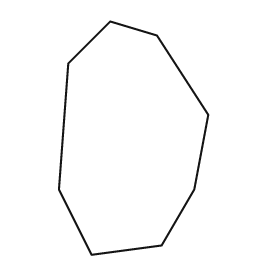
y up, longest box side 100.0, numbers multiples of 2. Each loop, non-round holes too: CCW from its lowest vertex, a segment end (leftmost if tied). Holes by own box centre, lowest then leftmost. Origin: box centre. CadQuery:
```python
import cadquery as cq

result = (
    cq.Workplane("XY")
    .moveTo(-18.0, -50.0)
    .lineTo(12.0, -46.0)
    .lineTo(26.0, -22.0)
    .lineTo(32.0, 10.0)
    .lineTo(10.0, 44.0)
    .lineTo(-10.0, 50.0)
    .lineTo(-28.0, 32.0)
    .lineTo(-32.0, -22.0)
    .close()
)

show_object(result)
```